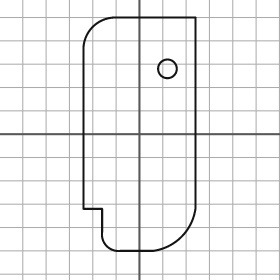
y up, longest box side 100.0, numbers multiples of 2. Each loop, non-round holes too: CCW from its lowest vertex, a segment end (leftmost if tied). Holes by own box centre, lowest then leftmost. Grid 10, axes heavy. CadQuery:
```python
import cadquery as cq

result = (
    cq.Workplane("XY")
    .moveTo(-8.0, -50.0)
    .lineTo(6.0, -50.0)
    .threePointArc((18.0, -44.0), (24.0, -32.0))
    .lineTo(24.0, 50.0)
    .lineTo(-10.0, 50.0)
    .threePointArc((-20.0, 46.0), (-24.0, 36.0))
    .lineTo(-24.0, -32.0)
    .lineTo(-16.0, -32.0)
    .lineTo(-16.0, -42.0)
    .threePointArc((-14.0, -48.0), (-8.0, -50.0))
    .close()
    .moveTo(12.0, 28.0)
    .circle(4.0)
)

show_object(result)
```